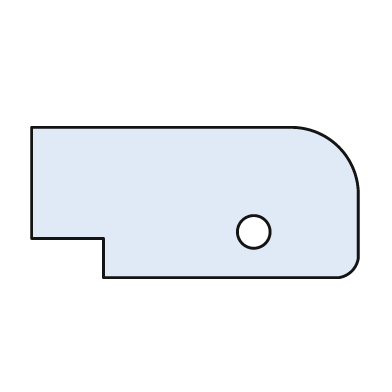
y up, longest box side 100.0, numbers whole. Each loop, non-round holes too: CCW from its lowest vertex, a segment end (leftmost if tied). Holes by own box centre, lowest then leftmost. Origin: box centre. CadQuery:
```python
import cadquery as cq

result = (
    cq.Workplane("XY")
    .moveTo(-28.0, -23.0)
    .lineTo(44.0, -23.0)
    .threePointArc((48.0, -21.0), (50.0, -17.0))
    .lineTo(50.0, 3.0)
    .threePointArc((44.0, 17.0), (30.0, 23.0))
    .lineTo(-50.0, 23.0)
    .lineTo(-50.0, -11.0)
    .lineTo(-28.0, -11.0)
    .close()
    .moveTo(18.0, -9.0)
    .circle(5.0)
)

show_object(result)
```